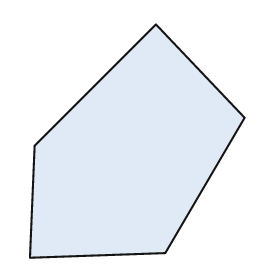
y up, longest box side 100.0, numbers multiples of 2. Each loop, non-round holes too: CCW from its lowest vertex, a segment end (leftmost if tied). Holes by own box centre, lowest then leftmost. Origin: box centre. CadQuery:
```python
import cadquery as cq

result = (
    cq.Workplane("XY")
    .moveTo(-46.0, -50.0)
    .lineTo(12.0, -48.0)
    .lineTo(46.0, 10.0)
    .lineTo(8.0, 50.0)
    .lineTo(-44.0, -2.0)
    .close()
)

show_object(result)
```